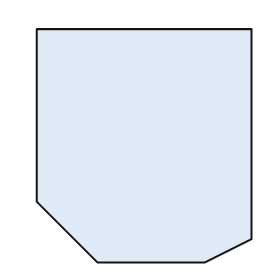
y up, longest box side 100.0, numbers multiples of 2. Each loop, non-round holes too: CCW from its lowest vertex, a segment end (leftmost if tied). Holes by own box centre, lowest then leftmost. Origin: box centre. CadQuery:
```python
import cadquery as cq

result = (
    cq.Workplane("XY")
    .moveTo(-20.0, -50.0)
    .lineTo(26.0, -50.0)
    .lineTo(46.0, -40.0)
    .lineTo(46.0, 50.0)
    .lineTo(-46.0, 50.0)
    .lineTo(-46.0, -24.0)
    .close()
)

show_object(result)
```